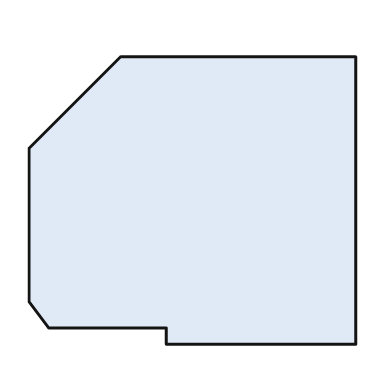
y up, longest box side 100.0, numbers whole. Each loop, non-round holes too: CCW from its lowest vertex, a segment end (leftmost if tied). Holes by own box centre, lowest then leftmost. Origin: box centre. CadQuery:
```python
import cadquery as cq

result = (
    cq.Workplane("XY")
    .moveTo(-8.0, -44.0)
    .lineTo(50.0, -44.0)
    .lineTo(50.0, 44.0)
    .lineTo(-22.0, 44.0)
    .lineTo(-50.0, 16.0)
    .lineTo(-50.0, -31.0)
    .lineTo(-44.0, -39.0)
    .lineTo(-8.0, -39.0)
    .close()
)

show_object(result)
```